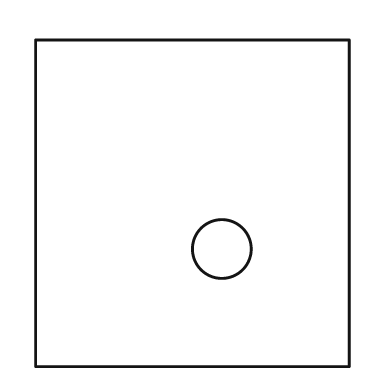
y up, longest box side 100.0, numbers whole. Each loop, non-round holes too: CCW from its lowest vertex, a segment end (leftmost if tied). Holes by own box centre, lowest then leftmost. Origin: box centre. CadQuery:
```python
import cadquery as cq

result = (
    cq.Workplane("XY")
    .moveTo(-48.0, -50.0)
    .lineTo(48.0, -50.0)
    .lineTo(48.0, 50.0)
    .lineTo(-48.0, 50.0)
    .close()
    .moveTo(9.0, -14.0)
    .circle(9.0)
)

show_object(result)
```